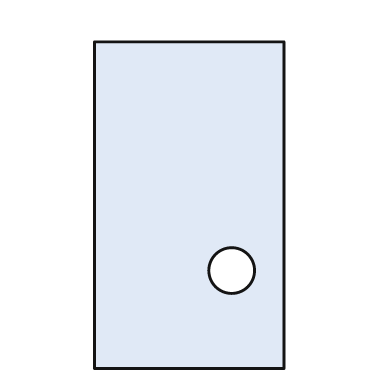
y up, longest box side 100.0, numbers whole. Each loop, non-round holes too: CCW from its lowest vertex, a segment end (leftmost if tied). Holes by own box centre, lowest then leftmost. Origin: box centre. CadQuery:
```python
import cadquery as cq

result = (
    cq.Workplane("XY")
    .moveTo(-29.0, -50.0)
    .lineTo(29.0, -50.0)
    .lineTo(29.0, 50.0)
    .lineTo(-29.0, 50.0)
    .close()
    .moveTo(13.0, -20.0)
    .circle(7.0)
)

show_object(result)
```